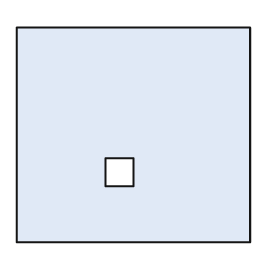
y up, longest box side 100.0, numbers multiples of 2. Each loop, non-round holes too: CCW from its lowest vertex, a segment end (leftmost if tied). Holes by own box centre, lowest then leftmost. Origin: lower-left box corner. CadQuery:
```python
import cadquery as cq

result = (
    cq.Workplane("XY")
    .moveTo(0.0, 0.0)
    .lineTo(100.0, 0.0)
    .lineTo(100.0, 92.0)
    .lineTo(0.0, 92.0)
    .close()
    .moveTo(38.0, 24.0)
    .lineTo(50.0, 24.0)
    .lineTo(50.0, 36.0)
    .lineTo(38.0, 36.0)
    .close()
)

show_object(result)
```